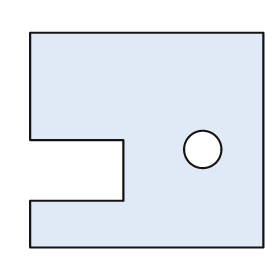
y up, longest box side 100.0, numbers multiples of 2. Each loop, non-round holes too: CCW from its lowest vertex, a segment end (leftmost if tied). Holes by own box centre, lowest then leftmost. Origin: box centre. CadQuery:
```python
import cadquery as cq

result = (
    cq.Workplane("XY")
    .moveTo(-50.0, -46.0)
    .lineTo(50.0, -46.0)
    .lineTo(50.0, 46.0)
    .lineTo(-50.0, 46.0)
    .lineTo(-50.0, 0.0)
    .lineTo(-10.0, 0.0)
    .lineTo(-10.0, -26.0)
    .lineTo(-50.0, -26.0)
    .close()
    .moveTo(24.0, -4.0)
    .circle(8.0)
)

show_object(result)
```